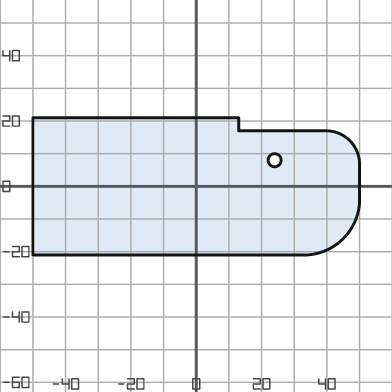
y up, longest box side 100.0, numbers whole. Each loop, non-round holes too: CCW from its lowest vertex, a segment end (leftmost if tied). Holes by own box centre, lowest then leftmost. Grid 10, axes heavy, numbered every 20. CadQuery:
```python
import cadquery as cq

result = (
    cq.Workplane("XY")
    .moveTo(-50.0, -21.0)
    .lineTo(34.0, -21.0)
    .threePointArc((45.0, -16.0), (50.0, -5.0))
    .lineTo(50.0, 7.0)
    .threePointArc((47.0, 14.0), (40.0, 17.0))
    .lineTo(13.0, 17.0)
    .lineTo(13.0, 21.0)
    .lineTo(-50.0, 21.0)
    .close()
    .moveTo(24.0, 8.0)
    .circle(2.0)
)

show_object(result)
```